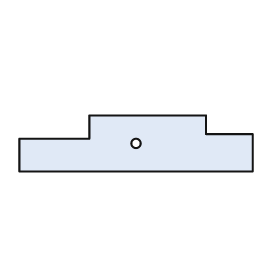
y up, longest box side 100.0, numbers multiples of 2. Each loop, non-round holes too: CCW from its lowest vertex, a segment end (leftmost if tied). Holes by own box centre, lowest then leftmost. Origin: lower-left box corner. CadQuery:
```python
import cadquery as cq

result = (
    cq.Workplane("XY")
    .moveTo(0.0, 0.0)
    .lineTo(100.0, 0.0)
    .lineTo(100.0, 16.0)
    .lineTo(80.0, 16.0)
    .lineTo(80.0, 24.0)
    .lineTo(30.0, 24.0)
    .lineTo(30.0, 14.0)
    .lineTo(0.0, 14.0)
    .close()
    .moveTo(50.0, 12.0)
    .circle(2.0)
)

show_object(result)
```